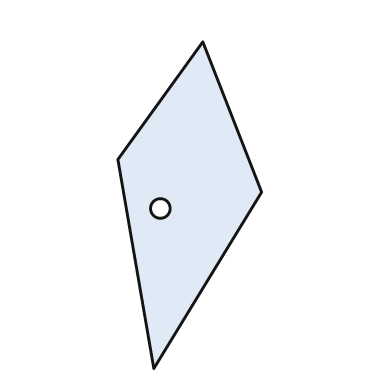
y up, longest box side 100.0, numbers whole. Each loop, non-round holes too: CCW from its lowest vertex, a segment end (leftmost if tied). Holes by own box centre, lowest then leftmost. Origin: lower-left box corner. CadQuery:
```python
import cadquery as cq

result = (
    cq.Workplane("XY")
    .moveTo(11.0, 0.0)
    .lineTo(44.0, 54.0)
    .lineTo(26.0, 100.0)
    .lineTo(0.0, 64.0)
    .close()
    .moveTo(13.0, 49.0)
    .circle(3.0)
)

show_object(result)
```